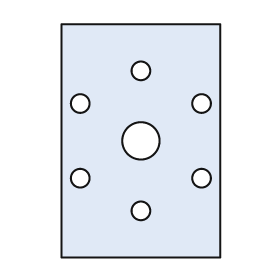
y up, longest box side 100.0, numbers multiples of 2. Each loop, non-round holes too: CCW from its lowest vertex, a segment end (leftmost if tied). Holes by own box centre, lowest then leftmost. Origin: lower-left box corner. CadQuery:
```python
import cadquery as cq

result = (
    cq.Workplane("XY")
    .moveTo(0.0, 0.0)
    .lineTo(68.0, 0.0)
    .lineTo(68.0, 100.0)
    .lineTo(0.0, 100.0)
    .close()
    .moveTo(34.0, 20.0)
    .circle(4.0)
    .moveTo(8.0, 34.0)
    .circle(4.0)
    .moveTo(60.0, 34.0)
    .circle(4.0)
    .moveTo(34.0, 50.0)
    .circle(8.0)
    .moveTo(8.0, 66.0)
    .circle(4.0)
    .moveTo(60.0, 66.0)
    .circle(4.0)
    .moveTo(34.0, 80.0)
    .circle(4.0)
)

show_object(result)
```